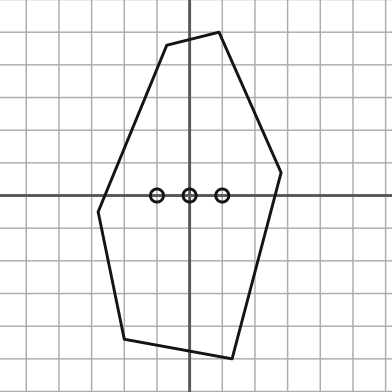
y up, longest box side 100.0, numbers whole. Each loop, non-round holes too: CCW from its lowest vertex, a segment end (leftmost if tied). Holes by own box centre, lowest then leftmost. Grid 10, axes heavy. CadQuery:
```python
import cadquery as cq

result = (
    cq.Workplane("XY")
    .moveTo(13.0, -50.0)
    .lineTo(28.0, 7.0)
    .lineTo(9.0, 50.0)
    .lineTo(-7.0, 46.0)
    .lineTo(-28.0, -5.0)
    .lineTo(-20.0, -44.0)
    .close()
    .moveTo(-10.0, 0.0)
    .circle(2.0)
    .moveTo(0.0, 0.0)
    .circle(2.0)
    .moveTo(10.0, 0.0)
    .circle(2.0)
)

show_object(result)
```